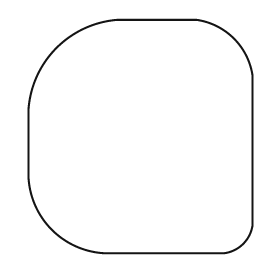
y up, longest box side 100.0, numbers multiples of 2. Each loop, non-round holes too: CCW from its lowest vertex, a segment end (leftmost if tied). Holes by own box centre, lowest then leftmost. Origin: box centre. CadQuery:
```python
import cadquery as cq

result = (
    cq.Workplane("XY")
    .moveTo(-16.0, -50.0)
    .lineTo(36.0, -50.0)
    .threePointArc((44.0, -46.0), (48.0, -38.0))
    .lineTo(48.0, 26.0)
    .threePointArc((40.0, 42.0), (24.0, 50.0))
    .lineTo(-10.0, 50.0)
    .threePointArc((-36.0, 38.0), (-48.0, 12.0))
    .lineTo(-48.0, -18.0)
    .threePointArc((-38.0, -40.0), (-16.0, -50.0))
    .close()
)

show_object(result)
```